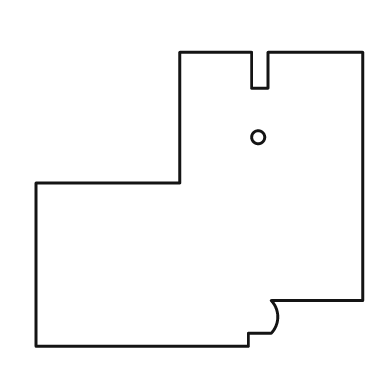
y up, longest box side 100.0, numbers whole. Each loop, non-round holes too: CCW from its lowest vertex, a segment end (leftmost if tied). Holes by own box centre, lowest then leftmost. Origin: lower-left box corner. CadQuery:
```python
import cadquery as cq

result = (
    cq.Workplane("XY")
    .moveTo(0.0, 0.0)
    .lineTo(65.0, 0.0)
    .lineTo(65.0, 4.0)
    .lineTo(72.0, 4.0)
    .threePointArc((74.0, 9.0), (72.0, 14.0))
    .lineTo(100.0, 14.0)
    .lineTo(100.0, 90.0)
    .lineTo(71.0, 90.0)
    .lineTo(71.0, 79.0)
    .lineTo(66.0, 79.0)
    .lineTo(66.0, 90.0)
    .lineTo(44.0, 90.0)
    .lineTo(44.0, 50.0)
    .lineTo(0.0, 50.0)
    .close()
    .moveTo(68.0, 64.0)
    .circle(2.0)
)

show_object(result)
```